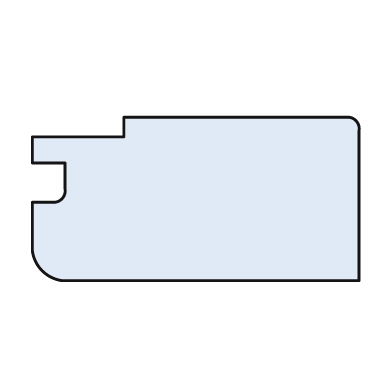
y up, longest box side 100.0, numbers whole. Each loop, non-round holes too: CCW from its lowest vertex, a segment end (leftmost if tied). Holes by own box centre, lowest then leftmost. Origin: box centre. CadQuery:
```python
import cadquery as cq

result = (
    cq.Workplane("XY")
    .moveTo(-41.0, -25.0)
    .lineTo(50.0, -25.0)
    .lineTo(50.0, 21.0)
    .threePointArc((49.0, 24.0), (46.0, 25.0))
    .lineTo(-22.0, 25.0)
    .lineTo(-22.0, 19.0)
    .lineTo(-50.0, 19.0)
    .lineTo(-50.0, 11.0)
    .lineTo(-40.0, 11.0)
    .lineTo(-40.0, 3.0)
    .threePointArc((-41.0, 0.0), (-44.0, -1.0))
    .lineTo(-50.0, -1.0)
    .lineTo(-50.0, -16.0)
    .threePointArc((-47.0, -22.0), (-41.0, -25.0))
    .close()
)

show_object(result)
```